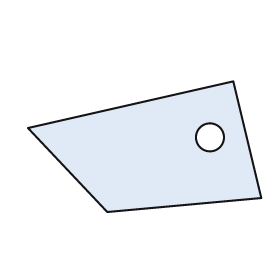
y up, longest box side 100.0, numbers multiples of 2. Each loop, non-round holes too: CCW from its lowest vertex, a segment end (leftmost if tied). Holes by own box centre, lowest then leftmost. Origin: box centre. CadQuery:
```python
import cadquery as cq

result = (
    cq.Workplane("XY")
    .moveTo(-16.0, -28.0)
    .lineTo(50.0, -22.0)
    .lineTo(38.0, 28.0)
    .lineTo(-50.0, 8.0)
    .close()
    .moveTo(28.0, 4.0)
    .circle(6.0)
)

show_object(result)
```